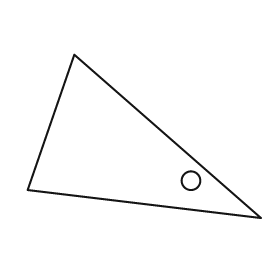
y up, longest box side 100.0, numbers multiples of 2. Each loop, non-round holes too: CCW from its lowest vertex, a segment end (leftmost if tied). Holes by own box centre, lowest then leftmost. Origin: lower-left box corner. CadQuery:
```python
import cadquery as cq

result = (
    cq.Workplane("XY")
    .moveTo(100.0, 0.0)
    .lineTo(20.0, 70.0)
    .lineTo(0.0, 12.0)
    .close()
    .moveTo(70.0, 16.0)
    .circle(4.0)
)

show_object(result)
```